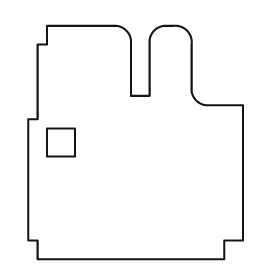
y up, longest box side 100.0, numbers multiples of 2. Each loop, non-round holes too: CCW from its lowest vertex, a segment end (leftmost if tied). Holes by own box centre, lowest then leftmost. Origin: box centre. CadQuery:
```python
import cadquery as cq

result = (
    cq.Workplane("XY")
    .moveTo(-42.0, -50.0)
    .lineTo(38.0, -50.0)
    .lineTo(38.0, -42.0)
    .lineTo(46.0, -42.0)
    .lineTo(46.0, 16.0)
    .lineTo(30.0, 16.0)
    .threePointArc((26.0, 18.0), (24.0, 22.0))
    .lineTo(24.0, 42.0)
    .threePointArc((22.0, 48.0), (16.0, 50.0))
    .lineTo(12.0, 50.0)
    .threePointArc((8.0, 48.0), (6.0, 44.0))
    .lineTo(6.0, 20.0)
    .lineTo(-2.0, 20.0)
    .lineTo(-2.0, 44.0)
    .threePointArc((-4.0, 48.0), (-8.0, 50.0))
    .lineTo(-38.0, 50.0)
    .lineTo(-38.0, 42.0)
    .lineTo(-42.0, 42.0)
    .lineTo(-42.0, 10.0)
    .lineTo(-46.0, 10.0)
    .lineTo(-46.0, -42.0)
    .lineTo(-42.0, -42.0)
    .close()
    .moveTo(-38.0, -6.0)
    .lineTo(-26.0, -6.0)
    .lineTo(-26.0, 6.0)
    .lineTo(-38.0, 6.0)
    .close()
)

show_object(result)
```